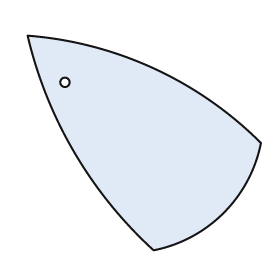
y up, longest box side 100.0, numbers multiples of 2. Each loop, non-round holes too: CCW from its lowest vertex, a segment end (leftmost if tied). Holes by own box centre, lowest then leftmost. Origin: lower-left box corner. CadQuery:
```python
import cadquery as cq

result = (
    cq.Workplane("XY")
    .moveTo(54.0, 0.0)
    .threePointArc((84.0, 16.0), (100.0, 46.0))
    .threePointArc((54.0, 78.0), (0.0, 92.0))
    .threePointArc((20.0, 42.0), (54.0, 0.0))
    .close()
    .moveTo(16.0, 72.0)
    .circle(2.0)
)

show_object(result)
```